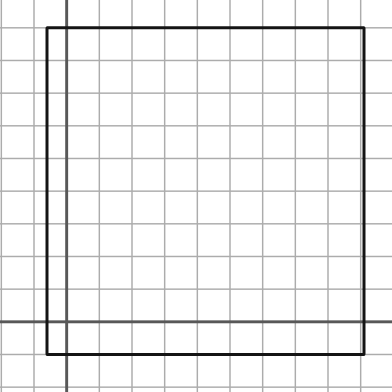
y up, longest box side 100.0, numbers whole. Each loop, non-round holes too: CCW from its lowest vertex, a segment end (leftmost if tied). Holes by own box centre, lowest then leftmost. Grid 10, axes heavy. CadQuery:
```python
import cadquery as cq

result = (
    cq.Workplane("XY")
    .moveTo(-6.0, -10.0)
    .lineTo(91.0, -10.0)
    .lineTo(91.0, 90.0)
    .lineTo(-6.0, 90.0)
    .close()
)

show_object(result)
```